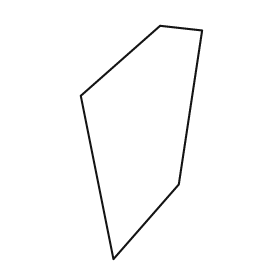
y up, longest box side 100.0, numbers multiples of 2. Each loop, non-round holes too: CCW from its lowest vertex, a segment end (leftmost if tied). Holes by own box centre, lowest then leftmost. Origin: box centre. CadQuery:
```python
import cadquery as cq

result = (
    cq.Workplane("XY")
    .moveTo(-12.0, -50.0)
    .lineTo(16.0, -18.0)
    .lineTo(26.0, 48.0)
    .lineTo(8.0, 50.0)
    .lineTo(-26.0, 20.0)
    .close()
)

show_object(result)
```